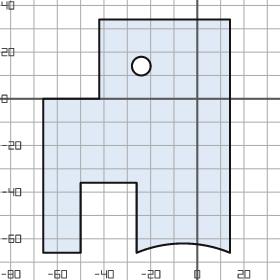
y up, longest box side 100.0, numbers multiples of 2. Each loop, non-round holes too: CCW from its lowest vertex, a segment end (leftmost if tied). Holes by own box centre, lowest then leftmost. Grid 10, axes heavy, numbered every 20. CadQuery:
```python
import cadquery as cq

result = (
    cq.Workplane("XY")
    .moveTo(-66.0, -66.0)
    .lineTo(-50.0, -66.0)
    .lineTo(-50.0, -36.0)
    .lineTo(-26.0, -36.0)
    .lineTo(-26.0, -66.0)
    .threePointArc((-6.0, -62.0), (14.0, -66.0))
    .lineTo(14.0, 34.0)
    .lineTo(-42.0, 34.0)
    .lineTo(-42.0, 0.0)
    .lineTo(-66.0, 0.0)
    .close()
    .moveTo(-24.0, 14.0)
    .circle(4.0)
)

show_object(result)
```